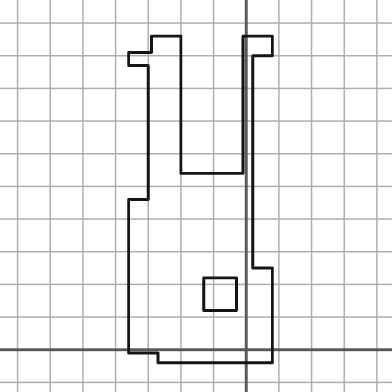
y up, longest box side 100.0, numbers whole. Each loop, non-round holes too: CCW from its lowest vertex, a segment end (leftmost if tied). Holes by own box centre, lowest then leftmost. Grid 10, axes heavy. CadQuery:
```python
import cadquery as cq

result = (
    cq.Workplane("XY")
    .moveTo(-27.0, -4.0)
    .lineTo(8.0, -4.0)
    .lineTo(8.0, 25.0)
    .lineTo(2.0, 25.0)
    .lineTo(2.0, 90.0)
    .lineTo(8.0, 90.0)
    .lineTo(8.0, 96.0)
    .lineTo(-1.0, 96.0)
    .lineTo(-1.0, 54.0)
    .lineTo(-20.0, 54.0)
    .lineTo(-20.0, 96.0)
    .lineTo(-29.0, 96.0)
    .lineTo(-29.0, 91.0)
    .lineTo(-36.0, 91.0)
    .lineTo(-36.0, 87.0)
    .lineTo(-30.0, 87.0)
    .lineTo(-30.0, 46.0)
    .lineTo(-36.0, 46.0)
    .lineTo(-36.0, -1.0)
    .lineTo(-27.0, -1.0)
    .close()
    .moveTo(-13.0, 12.0)
    .lineTo(-3.0, 12.0)
    .lineTo(-3.0, 22.0)
    .lineTo(-13.0, 22.0)
    .close()
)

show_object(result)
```